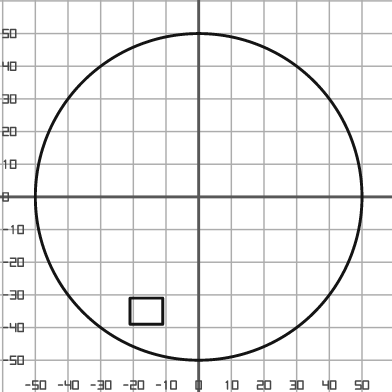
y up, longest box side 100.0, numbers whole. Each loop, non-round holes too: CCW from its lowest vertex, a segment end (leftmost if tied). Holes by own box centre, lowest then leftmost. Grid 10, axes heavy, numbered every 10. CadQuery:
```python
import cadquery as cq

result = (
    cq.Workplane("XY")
    .moveTo(0.0, 0.0)
    .circle(50.0)
    .moveTo(-21.0, -39.0)
    .lineTo(-11.0, -39.0)
    .lineTo(-11.0, -31.0)
    .lineTo(-21.0, -31.0)
    .close()
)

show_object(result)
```